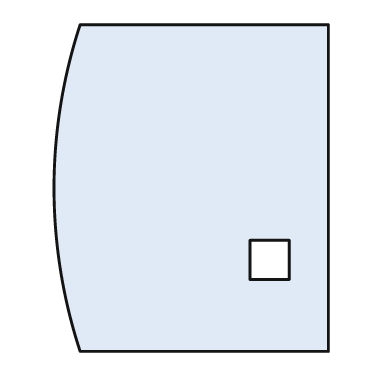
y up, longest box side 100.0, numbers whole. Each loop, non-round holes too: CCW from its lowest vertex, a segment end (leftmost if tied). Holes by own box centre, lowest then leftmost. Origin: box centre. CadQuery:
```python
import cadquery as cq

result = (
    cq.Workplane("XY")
    .moveTo(-34.0, -50.0)
    .lineTo(42.0, -50.0)
    .lineTo(42.0, 50.0)
    .lineTo(-34.0, 50.0)
    .threePointArc((-42.0, 0.0), (-34.0, -50.0))
    .close()
    .moveTo(18.0, -28.0)
    .lineTo(30.0, -28.0)
    .lineTo(30.0, -16.0)
    .lineTo(18.0, -16.0)
    .close()
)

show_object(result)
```